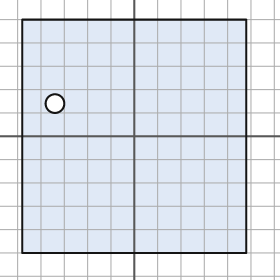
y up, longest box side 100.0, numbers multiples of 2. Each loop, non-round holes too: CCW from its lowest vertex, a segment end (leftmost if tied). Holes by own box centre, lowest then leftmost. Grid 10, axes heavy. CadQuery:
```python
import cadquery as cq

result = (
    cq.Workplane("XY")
    .moveTo(-48.0, -50.0)
    .lineTo(48.0, -50.0)
    .lineTo(48.0, 50.0)
    .lineTo(-48.0, 50.0)
    .close()
    .moveTo(-34.0, 14.0)
    .circle(4.0)
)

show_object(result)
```